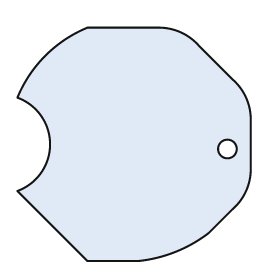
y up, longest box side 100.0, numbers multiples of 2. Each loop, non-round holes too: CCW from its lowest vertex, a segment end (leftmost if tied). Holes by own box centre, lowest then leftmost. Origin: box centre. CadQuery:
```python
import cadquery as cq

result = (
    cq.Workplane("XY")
    .moveTo(-20.0, -50.0)
    .lineTo(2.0, -50.0)
    .threePointArc((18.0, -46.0), (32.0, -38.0))
    .lineTo(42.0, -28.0)
    .threePointArc((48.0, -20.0), (50.0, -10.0))
    .lineTo(50.0, 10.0)
    .threePointArc((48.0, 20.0), (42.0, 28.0))
    .lineTo(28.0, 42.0)
    .threePointArc((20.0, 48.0), (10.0, 50.0))
    .lineTo(-20.0, 50.0)
    .threePointArc((-38.0, 38.0), (-50.0, 20.0))
    .threePointArc((-36.0, 0.0), (-50.0, -20.0))
    .close()
    .moveTo(40.0, -2.0)
    .circle(4.0)
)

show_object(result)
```